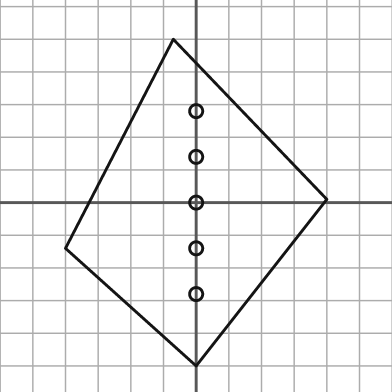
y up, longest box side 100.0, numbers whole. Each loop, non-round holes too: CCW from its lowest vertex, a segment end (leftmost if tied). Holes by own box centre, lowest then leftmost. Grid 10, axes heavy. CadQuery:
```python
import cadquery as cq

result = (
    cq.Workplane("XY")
    .moveTo(0.0, -50.0)
    .lineTo(40.0, 1.0)
    .lineTo(-7.0, 50.0)
    .lineTo(-40.0, -14.0)
    .close()
    .moveTo(0.0, -28.0)
    .circle(2.0)
    .moveTo(0.0, -14.0)
    .circle(2.0)
    .moveTo(0.0, 0.0)
    .circle(2.0)
    .moveTo(0.0, 14.0)
    .circle(2.0)
    .moveTo(0.0, 28.0)
    .circle(2.0)
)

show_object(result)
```